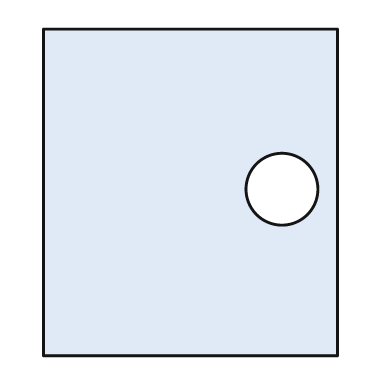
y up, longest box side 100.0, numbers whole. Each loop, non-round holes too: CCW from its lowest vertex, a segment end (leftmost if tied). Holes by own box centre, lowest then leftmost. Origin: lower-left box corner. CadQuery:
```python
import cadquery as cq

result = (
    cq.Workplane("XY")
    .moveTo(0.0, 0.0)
    .lineTo(90.0, 0.0)
    .lineTo(90.0, 100.0)
    .lineTo(0.0, 100.0)
    .close()
    .moveTo(73.0, 51.0)
    .circle(11.0)
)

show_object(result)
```